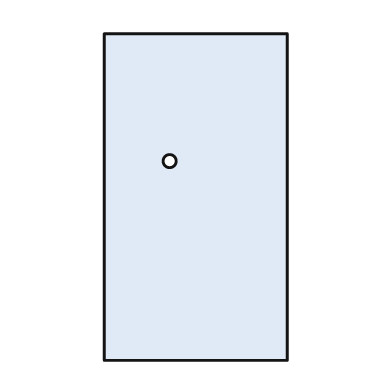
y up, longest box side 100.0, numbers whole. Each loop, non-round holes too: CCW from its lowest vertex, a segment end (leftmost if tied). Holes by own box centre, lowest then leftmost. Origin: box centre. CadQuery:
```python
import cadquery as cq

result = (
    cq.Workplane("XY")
    .moveTo(-28.0, -50.0)
    .lineTo(28.0, -50.0)
    .lineTo(28.0, 50.0)
    .lineTo(-28.0, 50.0)
    .close()
    .moveTo(-8.0, 11.0)
    .circle(2.0)
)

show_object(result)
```